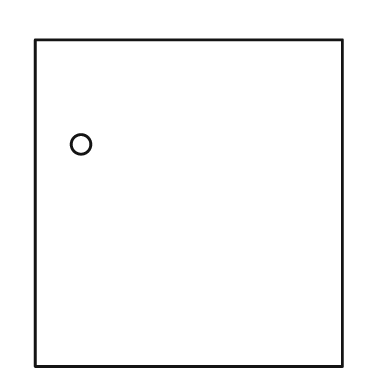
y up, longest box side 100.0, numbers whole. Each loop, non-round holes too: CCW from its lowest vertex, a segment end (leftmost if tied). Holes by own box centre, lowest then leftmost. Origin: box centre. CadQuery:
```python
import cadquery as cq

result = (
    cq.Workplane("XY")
    .moveTo(-47.0, -50.0)
    .lineTo(47.0, -50.0)
    .lineTo(47.0, 50.0)
    .lineTo(-47.0, 50.0)
    .close()
    .moveTo(-33.0, 18.0)
    .circle(3.0)
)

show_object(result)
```